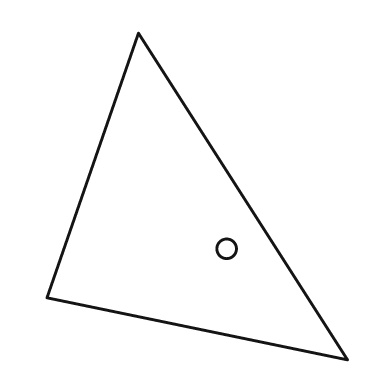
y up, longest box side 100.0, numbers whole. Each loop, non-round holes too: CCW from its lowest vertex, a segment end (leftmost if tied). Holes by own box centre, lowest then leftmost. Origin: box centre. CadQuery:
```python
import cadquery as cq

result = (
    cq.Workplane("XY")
    .moveTo(46.0, -50.0)
    .lineTo(-18.0, 50.0)
    .lineTo(-46.0, -31.0)
    .close()
    .moveTo(9.0, -16.0)
    .circle(3.0)
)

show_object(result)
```